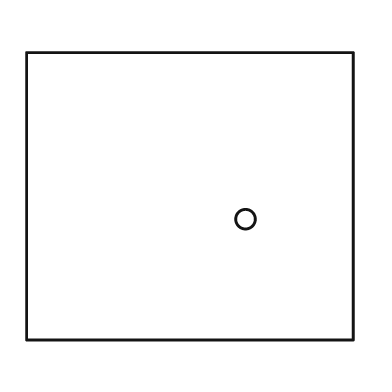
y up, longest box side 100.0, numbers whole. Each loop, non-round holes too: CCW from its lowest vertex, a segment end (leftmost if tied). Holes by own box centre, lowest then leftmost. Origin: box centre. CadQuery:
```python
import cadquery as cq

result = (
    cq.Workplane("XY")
    .moveTo(-50.0, -44.0)
    .lineTo(50.0, -44.0)
    .lineTo(50.0, 44.0)
    .lineTo(-50.0, 44.0)
    .close()
    .moveTo(17.0, -7.0)
    .circle(3.0)
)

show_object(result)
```